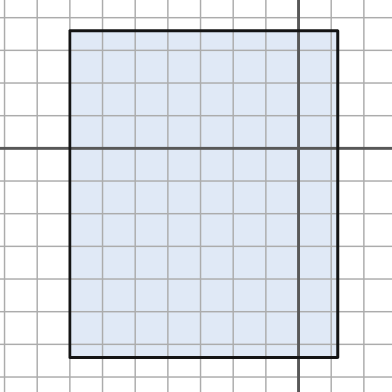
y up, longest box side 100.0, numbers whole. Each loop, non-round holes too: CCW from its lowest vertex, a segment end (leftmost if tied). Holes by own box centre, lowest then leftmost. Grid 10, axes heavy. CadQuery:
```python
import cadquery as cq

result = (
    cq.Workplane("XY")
    .moveTo(-70.0, -64.0)
    .lineTo(12.0, -64.0)
    .lineTo(12.0, 36.0)
    .lineTo(-70.0, 36.0)
    .close()
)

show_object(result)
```